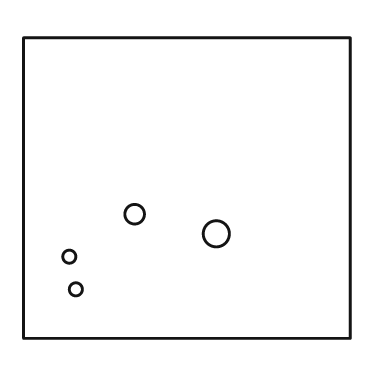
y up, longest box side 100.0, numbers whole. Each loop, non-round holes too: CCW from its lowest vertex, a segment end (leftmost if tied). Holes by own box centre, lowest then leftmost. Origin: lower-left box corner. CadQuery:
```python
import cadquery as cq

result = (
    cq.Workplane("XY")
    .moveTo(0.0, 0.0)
    .lineTo(100.0, 0.0)
    .lineTo(100.0, 92.0)
    .lineTo(0.0, 92.0)
    .close()
    .moveTo(16.0, 15.0)
    .circle(2.0)
    .moveTo(14.0, 25.0)
    .circle(2.0)
    .moveTo(59.0, 32.0)
    .circle(4.0)
    .moveTo(34.0, 38.0)
    .circle(3.0)
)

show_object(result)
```